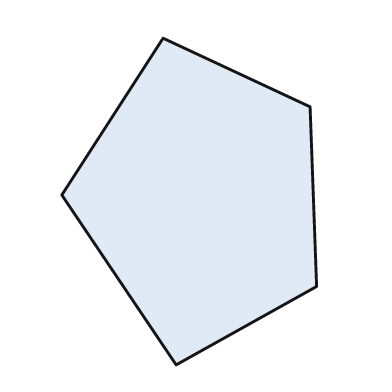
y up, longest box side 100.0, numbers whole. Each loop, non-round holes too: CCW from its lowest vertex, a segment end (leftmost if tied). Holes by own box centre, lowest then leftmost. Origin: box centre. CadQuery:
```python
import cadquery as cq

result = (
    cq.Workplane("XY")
    .moveTo(-4.0, -50.0)
    .lineTo(39.0, -26.0)
    .lineTo(37.0, 29.0)
    .lineTo(-8.0, 50.0)
    .lineTo(-39.0, 2.0)
    .close()
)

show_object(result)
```